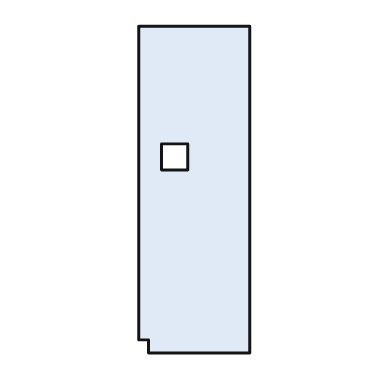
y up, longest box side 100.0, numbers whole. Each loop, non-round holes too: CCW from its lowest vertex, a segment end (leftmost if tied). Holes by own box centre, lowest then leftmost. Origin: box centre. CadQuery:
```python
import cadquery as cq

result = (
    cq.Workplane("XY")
    .moveTo(-14.0, -50.0)
    .lineTo(17.0, -50.0)
    .lineTo(17.0, 50.0)
    .lineTo(-17.0, 50.0)
    .lineTo(-17.0, -46.0)
    .lineTo(-14.0, -46.0)
    .close()
    .moveTo(-10.0, 6.0)
    .lineTo(-2.0, 6.0)
    .lineTo(-2.0, 14.0)
    .lineTo(-10.0, 14.0)
    .close()
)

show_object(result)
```